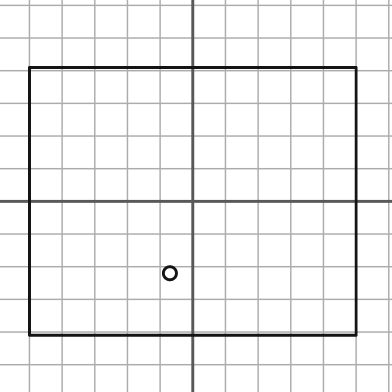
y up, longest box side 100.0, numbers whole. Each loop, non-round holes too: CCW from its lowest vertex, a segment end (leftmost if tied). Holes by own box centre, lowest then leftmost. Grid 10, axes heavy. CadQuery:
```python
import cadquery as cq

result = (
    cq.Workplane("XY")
    .moveTo(-50.0, -41.0)
    .lineTo(50.0, -41.0)
    .lineTo(50.0, 41.0)
    .lineTo(-50.0, 41.0)
    .close()
    .moveTo(-7.0, -22.0)
    .circle(2.0)
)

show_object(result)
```